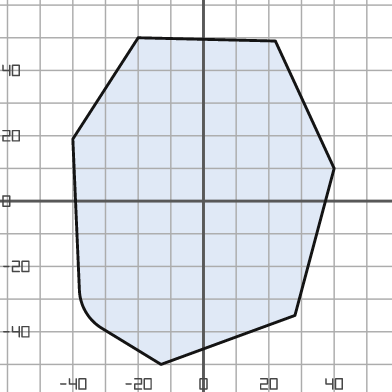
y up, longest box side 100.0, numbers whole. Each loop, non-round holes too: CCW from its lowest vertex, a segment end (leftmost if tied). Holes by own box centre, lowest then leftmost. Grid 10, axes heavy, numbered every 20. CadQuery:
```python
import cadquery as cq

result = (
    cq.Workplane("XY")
    .moveTo(-13.0, -50.0)
    .lineTo(28.0, -35.0)
    .lineTo(40.0, 10.0)
    .lineTo(22.0, 49.0)
    .lineTo(-20.0, 50.0)
    .lineTo(-40.0, 19.0)
    .lineTo(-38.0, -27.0)
    .threePointArc((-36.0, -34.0), (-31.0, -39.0))
    .close()
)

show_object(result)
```